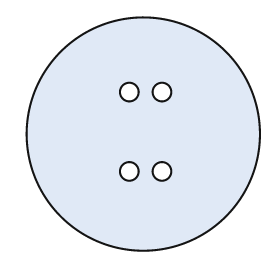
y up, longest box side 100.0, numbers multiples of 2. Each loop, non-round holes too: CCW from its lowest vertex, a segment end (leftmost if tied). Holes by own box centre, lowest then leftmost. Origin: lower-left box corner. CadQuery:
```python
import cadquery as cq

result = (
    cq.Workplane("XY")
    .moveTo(50.0, 50.0)
    .circle(50.0)
    .moveTo(44.0, 34.0)
    .circle(4.0)
    .moveTo(58.0, 34.0)
    .circle(4.0)
    .moveTo(44.0, 68.0)
    .circle(4.0)
    .moveTo(58.0, 68.0)
    .circle(4.0)
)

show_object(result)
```